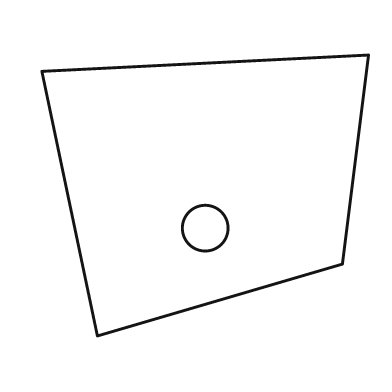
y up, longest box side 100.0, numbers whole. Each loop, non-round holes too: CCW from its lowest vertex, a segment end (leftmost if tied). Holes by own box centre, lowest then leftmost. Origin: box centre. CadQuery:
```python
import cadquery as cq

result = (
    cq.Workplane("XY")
    .moveTo(-33.0, -43.0)
    .lineTo(42.0, -21.0)
    .lineTo(50.0, 43.0)
    .lineTo(-50.0, 38.0)
    .close()
    .moveTo(0.0, -10.0)
    .circle(7.0)
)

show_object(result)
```